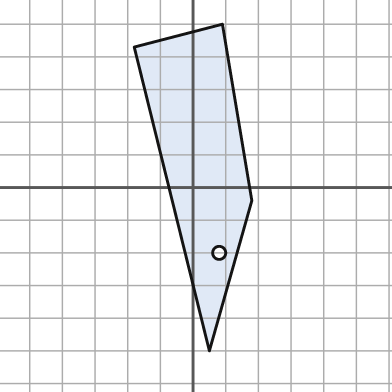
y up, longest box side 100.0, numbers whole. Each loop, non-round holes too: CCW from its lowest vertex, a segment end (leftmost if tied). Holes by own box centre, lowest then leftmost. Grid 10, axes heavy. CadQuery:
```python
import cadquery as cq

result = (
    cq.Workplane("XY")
    .moveTo(5.0, -50.0)
    .lineTo(18.0, -4.0)
    .lineTo(9.0, 50.0)
    .lineTo(-18.0, 43.0)
    .close()
    .moveTo(8.0, -20.0)
    .circle(2.0)
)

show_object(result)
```